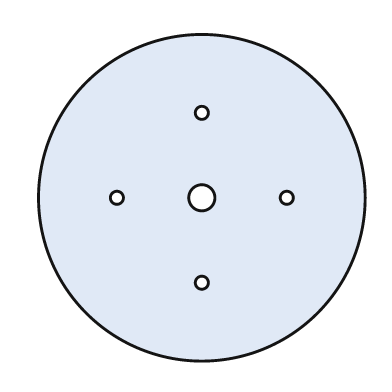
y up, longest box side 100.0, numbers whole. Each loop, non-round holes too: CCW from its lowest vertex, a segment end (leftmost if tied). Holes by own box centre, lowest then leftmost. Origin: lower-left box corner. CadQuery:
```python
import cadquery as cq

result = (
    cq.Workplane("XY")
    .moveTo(50.0, 50.0)
    .circle(50.0)
    .moveTo(50.0, 24.0)
    .circle(2.0)
    .moveTo(24.0, 50.0)
    .circle(2.0)
    .moveTo(50.0, 50.0)
    .circle(4.0)
    .moveTo(76.0, 50.0)
    .circle(2.0)
    .moveTo(50.0, 76.0)
    .circle(2.0)
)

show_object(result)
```